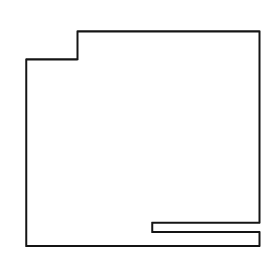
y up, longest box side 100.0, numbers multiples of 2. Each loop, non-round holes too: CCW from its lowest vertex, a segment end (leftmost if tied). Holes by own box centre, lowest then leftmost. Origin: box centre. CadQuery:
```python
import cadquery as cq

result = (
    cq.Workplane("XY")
    .moveTo(-50.0, -46.0)
    .lineTo(50.0, -46.0)
    .lineTo(50.0, -40.0)
    .lineTo(4.0, -40.0)
    .lineTo(4.0, -36.0)
    .lineTo(50.0, -36.0)
    .lineTo(50.0, 46.0)
    .lineTo(-28.0, 46.0)
    .lineTo(-28.0, 34.0)
    .lineTo(-50.0, 34.0)
    .close()
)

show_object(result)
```